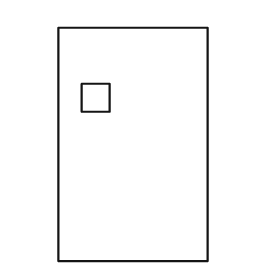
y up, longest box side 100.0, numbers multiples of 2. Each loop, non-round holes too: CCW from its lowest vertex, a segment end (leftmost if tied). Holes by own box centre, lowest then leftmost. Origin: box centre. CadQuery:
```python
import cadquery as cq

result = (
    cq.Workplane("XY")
    .moveTo(-32.0, -50.0)
    .lineTo(32.0, -50.0)
    .lineTo(32.0, 50.0)
    .lineTo(-32.0, 50.0)
    .close()
    .moveTo(-22.0, 14.0)
    .lineTo(-10.0, 14.0)
    .lineTo(-10.0, 26.0)
    .lineTo(-22.0, 26.0)
    .close()
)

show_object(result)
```